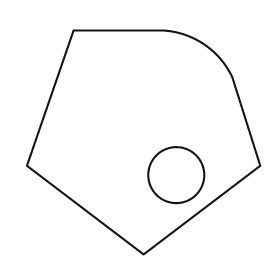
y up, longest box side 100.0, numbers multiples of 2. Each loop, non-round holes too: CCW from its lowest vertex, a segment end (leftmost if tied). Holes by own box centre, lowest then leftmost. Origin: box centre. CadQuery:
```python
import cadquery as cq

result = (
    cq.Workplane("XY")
    .moveTo(0.0, -48.0)
    .lineTo(50.0, -10.0)
    .lineTo(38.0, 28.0)
    .threePointArc((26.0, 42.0), (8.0, 48.0))
    .lineTo(-30.0, 48.0)
    .lineTo(-50.0, -10.0)
    .close()
    .moveTo(14.0, -14.0)
    .circle(12.0)
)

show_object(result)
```